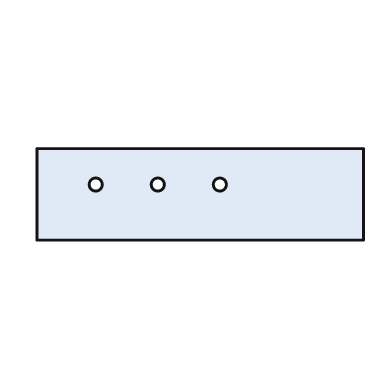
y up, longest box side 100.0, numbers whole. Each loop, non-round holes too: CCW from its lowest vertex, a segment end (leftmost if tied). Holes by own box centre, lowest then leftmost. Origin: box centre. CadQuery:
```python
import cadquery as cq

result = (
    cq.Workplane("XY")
    .moveTo(-50.0, -14.0)
    .lineTo(50.0, -14.0)
    .lineTo(50.0, 14.0)
    .lineTo(-50.0, 14.0)
    .close()
    .moveTo(-32.0, 3.0)
    .circle(2.0)
    .moveTo(-13.0, 3.0)
    .circle(2.0)
    .moveTo(6.0, 3.0)
    .circle(2.0)
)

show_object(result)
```